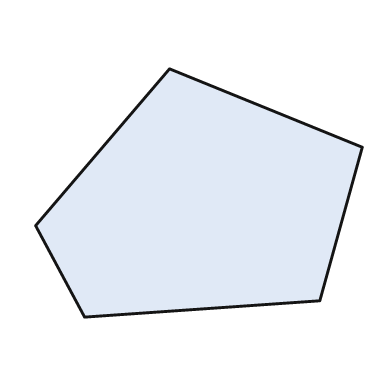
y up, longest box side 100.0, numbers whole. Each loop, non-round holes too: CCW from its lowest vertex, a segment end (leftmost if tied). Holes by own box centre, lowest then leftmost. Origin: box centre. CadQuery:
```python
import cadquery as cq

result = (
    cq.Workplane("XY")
    .moveTo(-35.0, -38.0)
    .lineTo(37.0, -33.0)
    .lineTo(50.0, 14.0)
    .lineTo(-9.0, 38.0)
    .lineTo(-50.0, -10.0)
    .close()
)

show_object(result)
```